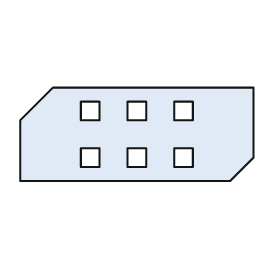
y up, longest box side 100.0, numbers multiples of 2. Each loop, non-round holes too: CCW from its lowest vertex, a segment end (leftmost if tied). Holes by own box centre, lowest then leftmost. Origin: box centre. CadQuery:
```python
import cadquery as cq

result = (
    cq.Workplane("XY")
    .moveTo(-50.0, -20.0)
    .lineTo(40.0, -20.0)
    .lineTo(50.0, -10.0)
    .lineTo(50.0, 20.0)
    .lineTo(-36.0, 20.0)
    .lineTo(-50.0, 6.0)
    .close()
    .moveTo(-24.0, -14.0)
    .lineTo(-16.0, -14.0)
    .lineTo(-16.0, -6.0)
    .lineTo(-24.0, -6.0)
    .close()
    .moveTo(-4.0, -14.0)
    .lineTo(4.0, -14.0)
    .lineTo(4.0, -6.0)
    .lineTo(-4.0, -6.0)
    .close()
    .moveTo(16.0, -14.0)
    .lineTo(24.0, -14.0)
    .lineTo(24.0, -6.0)
    .lineTo(16.0, -6.0)
    .close()
    .moveTo(-24.0, 6.0)
    .lineTo(-16.0, 6.0)
    .lineTo(-16.0, 14.0)
    .lineTo(-24.0, 14.0)
    .close()
    .moveTo(-4.0, 6.0)
    .lineTo(4.0, 6.0)
    .lineTo(4.0, 14.0)
    .lineTo(-4.0, 14.0)
    .close()
    .moveTo(16.0, 6.0)
    .lineTo(24.0, 6.0)
    .lineTo(24.0, 14.0)
    .lineTo(16.0, 14.0)
    .close()
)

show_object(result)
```